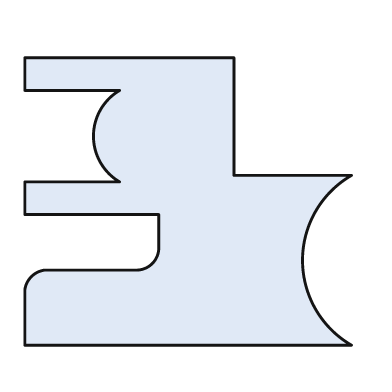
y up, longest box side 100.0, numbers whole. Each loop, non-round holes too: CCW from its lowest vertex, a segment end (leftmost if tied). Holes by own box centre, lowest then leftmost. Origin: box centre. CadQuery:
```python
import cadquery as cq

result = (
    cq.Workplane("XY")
    .moveTo(-50.0, -44.0)
    .lineTo(50.0, -44.0)
    .threePointArc((35.0, -18.0), (50.0, 8.0))
    .lineTo(14.0, 8.0)
    .lineTo(14.0, 44.0)
    .lineTo(-50.0, 44.0)
    .lineTo(-50.0, 34.0)
    .lineTo(-21.0, 34.0)
    .threePointArc((-29.0, 20.0), (-21.0, 6.0))
    .lineTo(-50.0, 6.0)
    .lineTo(-50.0, -4.0)
    .lineTo(-9.0, -4.0)
    .lineTo(-9.0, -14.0)
    .threePointArc((-11.0, -19.0), (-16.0, -21.0))
    .lineTo(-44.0, -21.0)
    .threePointArc((-48.0, -23.0), (-50.0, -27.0))
    .close()
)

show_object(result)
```